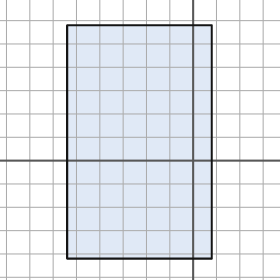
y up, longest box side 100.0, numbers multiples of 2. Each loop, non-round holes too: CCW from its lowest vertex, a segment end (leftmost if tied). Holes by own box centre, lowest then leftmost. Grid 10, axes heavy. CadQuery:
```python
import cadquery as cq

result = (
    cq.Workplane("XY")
    .moveTo(-54.0, -42.0)
    .lineTo(8.0, -42.0)
    .lineTo(8.0, 58.0)
    .lineTo(-54.0, 58.0)
    .close()
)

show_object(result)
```